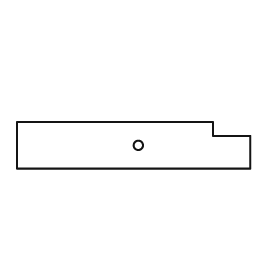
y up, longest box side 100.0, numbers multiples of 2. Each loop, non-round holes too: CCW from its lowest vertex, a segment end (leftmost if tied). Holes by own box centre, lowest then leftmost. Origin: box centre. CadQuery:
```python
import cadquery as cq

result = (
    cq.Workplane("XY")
    .moveTo(-50.0, -10.0)
    .lineTo(50.0, -10.0)
    .lineTo(50.0, 4.0)
    .lineTo(34.0, 4.0)
    .lineTo(34.0, 10.0)
    .lineTo(-50.0, 10.0)
    .close()
    .moveTo(2.0, 0.0)
    .circle(2.0)
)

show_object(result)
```